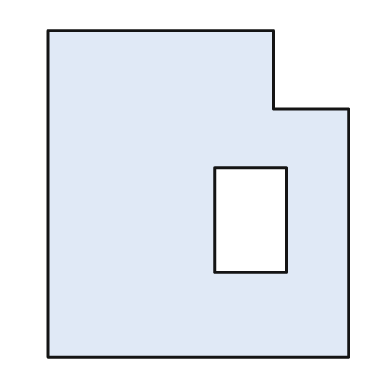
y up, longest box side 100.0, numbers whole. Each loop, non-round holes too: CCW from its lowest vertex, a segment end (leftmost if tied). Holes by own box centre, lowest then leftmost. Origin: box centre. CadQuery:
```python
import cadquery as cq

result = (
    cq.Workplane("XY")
    .moveTo(-46.0, -50.0)
    .lineTo(46.0, -50.0)
    .lineTo(46.0, 26.0)
    .lineTo(23.0, 26.0)
    .lineTo(23.0, 50.0)
    .lineTo(-46.0, 50.0)
    .close()
    .moveTo(5.0, -24.0)
    .lineTo(27.0, -24.0)
    .lineTo(27.0, 8.0)
    .lineTo(5.0, 8.0)
    .close()
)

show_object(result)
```